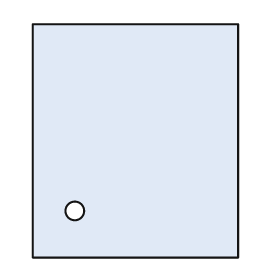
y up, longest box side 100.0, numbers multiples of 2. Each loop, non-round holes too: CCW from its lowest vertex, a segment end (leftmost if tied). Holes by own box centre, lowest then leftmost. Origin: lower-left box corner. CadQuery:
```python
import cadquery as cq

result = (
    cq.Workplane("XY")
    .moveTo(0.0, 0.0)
    .lineTo(88.0, 0.0)
    .lineTo(88.0, 100.0)
    .lineTo(0.0, 100.0)
    .close()
    .moveTo(18.0, 20.0)
    .circle(4.0)
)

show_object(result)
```